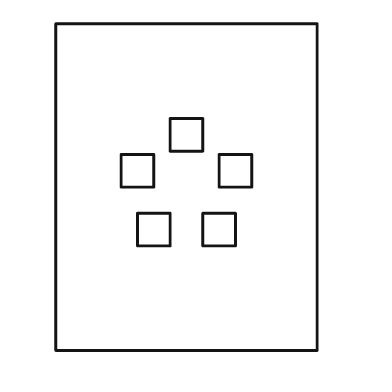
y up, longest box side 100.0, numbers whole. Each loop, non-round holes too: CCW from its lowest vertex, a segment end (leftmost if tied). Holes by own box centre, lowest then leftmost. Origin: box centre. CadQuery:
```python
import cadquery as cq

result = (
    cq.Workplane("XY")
    .moveTo(-40.0, -50.0)
    .lineTo(40.0, -50.0)
    .lineTo(40.0, 50.0)
    .lineTo(-40.0, 50.0)
    .close()
    .moveTo(-15.0, -18.0)
    .lineTo(-5.0, -18.0)
    .lineTo(-5.0, -8.0)
    .lineTo(-15.0, -8.0)
    .close()
    .moveTo(5.0, -18.0)
    .lineTo(15.0, -18.0)
    .lineTo(15.0, -8.0)
    .lineTo(5.0, -8.0)
    .close()
    .moveTo(-20.0, 0.0)
    .lineTo(-10.0, 0.0)
    .lineTo(-10.0, 10.0)
    .lineTo(-20.0, 10.0)
    .close()
    .moveTo(10.0, 0.0)
    .lineTo(20.0, 0.0)
    .lineTo(20.0, 10.0)
    .lineTo(10.0, 10.0)
    .close()
    .moveTo(-5.0, 11.0)
    .lineTo(5.0, 11.0)
    .lineTo(5.0, 21.0)
    .lineTo(-5.0, 21.0)
    .close()
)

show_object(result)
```